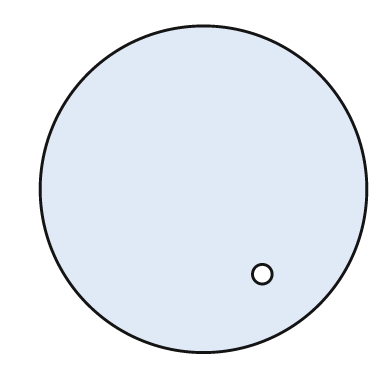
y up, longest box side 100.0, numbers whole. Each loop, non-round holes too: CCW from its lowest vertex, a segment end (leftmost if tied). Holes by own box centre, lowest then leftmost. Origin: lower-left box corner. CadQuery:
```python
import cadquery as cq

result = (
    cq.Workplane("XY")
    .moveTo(50.0, 50.0)
    .circle(50.0)
    .moveTo(68.0, 24.0)
    .circle(3.0)
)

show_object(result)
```